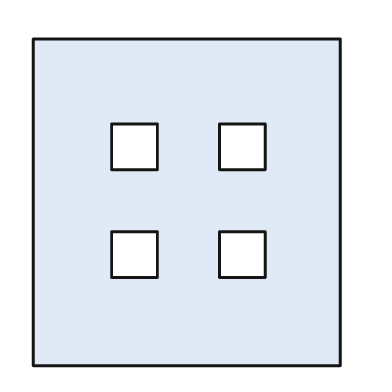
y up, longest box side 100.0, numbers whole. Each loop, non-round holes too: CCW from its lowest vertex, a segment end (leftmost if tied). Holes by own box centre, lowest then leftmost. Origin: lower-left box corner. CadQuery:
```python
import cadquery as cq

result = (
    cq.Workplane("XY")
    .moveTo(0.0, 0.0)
    .lineTo(94.0, 0.0)
    .lineTo(94.0, 100.0)
    .lineTo(0.0, 100.0)
    .close()
    .moveTo(24.0, 27.0)
    .lineTo(38.0, 27.0)
    .lineTo(38.0, 41.0)
    .lineTo(24.0, 41.0)
    .close()
    .moveTo(57.0, 27.0)
    .lineTo(71.0, 27.0)
    .lineTo(71.0, 41.0)
    .lineTo(57.0, 41.0)
    .close()
    .moveTo(24.0, 60.0)
    .lineTo(38.0, 60.0)
    .lineTo(38.0, 74.0)
    .lineTo(24.0, 74.0)
    .close()
    .moveTo(57.0, 60.0)
    .lineTo(71.0, 60.0)
    .lineTo(71.0, 74.0)
    .lineTo(57.0, 74.0)
    .close()
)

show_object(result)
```